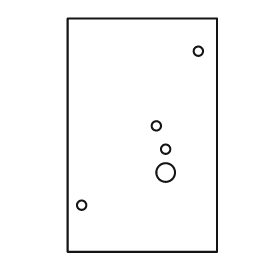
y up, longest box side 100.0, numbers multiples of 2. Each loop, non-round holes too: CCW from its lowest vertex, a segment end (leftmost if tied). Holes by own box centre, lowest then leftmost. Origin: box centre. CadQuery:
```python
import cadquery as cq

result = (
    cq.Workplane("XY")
    .moveTo(-32.0, -50.0)
    .lineTo(32.0, -50.0)
    .lineTo(32.0, 50.0)
    .lineTo(-32.0, 50.0)
    .close()
    .moveTo(-26.0, -30.0)
    .circle(2.0)
    .moveTo(10.0, -16.0)
    .circle(4.0)
    .moveTo(10.0, -6.0)
    .circle(2.0)
    .moveTo(6.0, 4.0)
    .circle(2.0)
    .moveTo(24.0, 36.0)
    .circle(2.0)
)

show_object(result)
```